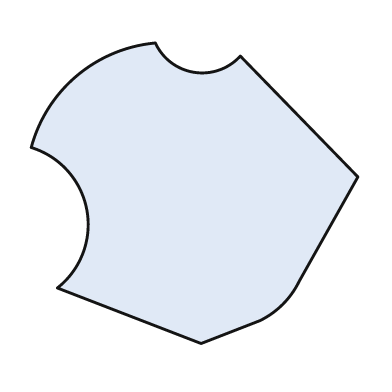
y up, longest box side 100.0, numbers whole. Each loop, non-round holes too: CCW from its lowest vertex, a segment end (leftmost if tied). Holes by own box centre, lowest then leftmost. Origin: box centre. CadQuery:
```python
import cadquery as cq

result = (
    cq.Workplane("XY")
    .moveTo(2.0, -46.0)
    .lineTo(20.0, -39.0)
    .threePointArc((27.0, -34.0), (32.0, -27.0))
    .lineTo(50.0, 5.0)
    .lineTo(14.0, 42.0)
    .threePointArc((0.0, 37.0), (-12.0, 46.0))
    .threePointArc((-36.0, 36.0), (-50.0, 14.0))
    .threePointArc((-33.0, -5.0), (-42.0, -29.0))
    .close()
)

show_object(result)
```